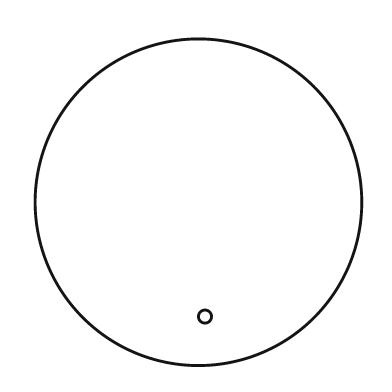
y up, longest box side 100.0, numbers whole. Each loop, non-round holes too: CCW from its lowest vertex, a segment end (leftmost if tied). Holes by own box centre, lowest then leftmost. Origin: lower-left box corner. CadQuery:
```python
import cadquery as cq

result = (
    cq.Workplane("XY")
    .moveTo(50.0, 50.0)
    .circle(50.0)
    .moveTo(52.0, 15.0)
    .circle(2.0)
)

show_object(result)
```